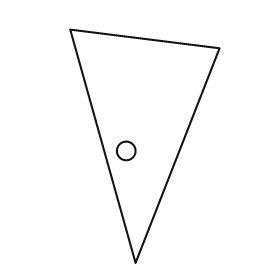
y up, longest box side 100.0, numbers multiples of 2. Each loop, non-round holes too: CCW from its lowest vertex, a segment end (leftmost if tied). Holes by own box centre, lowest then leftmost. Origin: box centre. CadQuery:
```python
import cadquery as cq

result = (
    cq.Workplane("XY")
    .moveTo(-4.0, -50.0)
    .lineTo(32.0, 42.0)
    .lineTo(-32.0, 50.0)
    .close()
    .moveTo(-8.0, -2.0)
    .circle(4.0)
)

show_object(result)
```